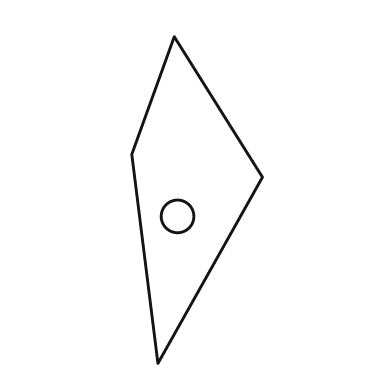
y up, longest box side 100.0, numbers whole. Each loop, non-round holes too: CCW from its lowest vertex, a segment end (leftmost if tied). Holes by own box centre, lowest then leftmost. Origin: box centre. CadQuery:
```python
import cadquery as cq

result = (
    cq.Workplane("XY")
    .moveTo(-12.0, -50.0)
    .lineTo(20.0, 7.0)
    .lineTo(-7.0, 50.0)
    .lineTo(-20.0, 14.0)
    .close()
    .moveTo(-6.0, -5.0)
    .circle(5.0)
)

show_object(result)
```